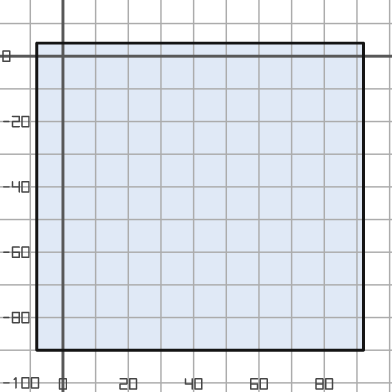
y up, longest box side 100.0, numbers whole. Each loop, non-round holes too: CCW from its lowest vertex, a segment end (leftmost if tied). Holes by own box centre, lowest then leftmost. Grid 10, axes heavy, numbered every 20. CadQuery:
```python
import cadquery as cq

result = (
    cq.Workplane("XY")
    .moveTo(-8.0, -90.0)
    .lineTo(92.0, -90.0)
    .lineTo(92.0, 4.0)
    .lineTo(-8.0, 4.0)
    .close()
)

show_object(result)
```